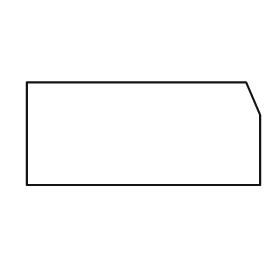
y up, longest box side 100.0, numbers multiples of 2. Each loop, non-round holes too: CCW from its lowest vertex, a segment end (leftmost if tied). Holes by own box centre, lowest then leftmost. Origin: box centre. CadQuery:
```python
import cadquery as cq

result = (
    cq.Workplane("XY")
    .moveTo(-50.0, -22.0)
    .lineTo(50.0, -22.0)
    .lineTo(50.0, 8.0)
    .lineTo(44.0, 22.0)
    .lineTo(-50.0, 22.0)
    .close()
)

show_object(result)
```